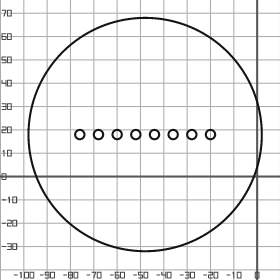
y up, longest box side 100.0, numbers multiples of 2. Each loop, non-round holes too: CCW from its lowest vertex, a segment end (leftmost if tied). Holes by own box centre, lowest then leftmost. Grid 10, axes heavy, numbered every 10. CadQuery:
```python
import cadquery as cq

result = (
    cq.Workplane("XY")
    .moveTo(-48.0, 18.0)
    .circle(50.0)
    .moveTo(-76.0, 18.0)
    .circle(2.0)
    .moveTo(-68.0, 18.0)
    .circle(2.0)
    .moveTo(-60.0, 18.0)
    .circle(2.0)
    .moveTo(-52.0, 18.0)
    .circle(2.0)
    .moveTo(-44.0, 18.0)
    .circle(2.0)
    .moveTo(-36.0, 18.0)
    .circle(2.0)
    .moveTo(-28.0, 18.0)
    .circle(2.0)
    .moveTo(-20.0, 18.0)
    .circle(2.0)
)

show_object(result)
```